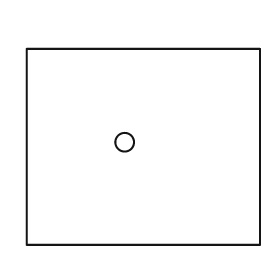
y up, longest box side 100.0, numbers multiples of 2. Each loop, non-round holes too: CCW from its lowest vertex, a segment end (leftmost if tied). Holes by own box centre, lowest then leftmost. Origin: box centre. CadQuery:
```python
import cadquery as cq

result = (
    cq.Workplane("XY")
    .moveTo(-50.0, -42.0)
    .lineTo(50.0, -42.0)
    .lineTo(50.0, 42.0)
    .lineTo(-50.0, 42.0)
    .close()
    .moveTo(-8.0, 2.0)
    .circle(4.0)
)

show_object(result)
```